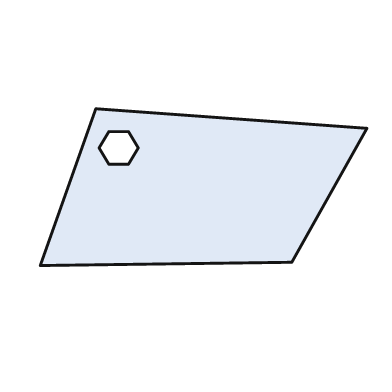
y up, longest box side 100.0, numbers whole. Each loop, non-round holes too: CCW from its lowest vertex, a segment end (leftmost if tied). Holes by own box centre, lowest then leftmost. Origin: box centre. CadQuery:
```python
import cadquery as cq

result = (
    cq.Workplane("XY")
    .moveTo(-50.0, -24.0)
    .lineTo(27.0, -23.0)
    .lineTo(50.0, 18.0)
    .lineTo(-33.0, 24.0)
    .close()
    .moveTo(-29.0, 7.0)
    .lineTo(-23.0, 7.0)
    .lineTo(-20.0, 12.0)
    .lineTo(-23.0, 17.0)
    .lineTo(-29.0, 17.0)
    .lineTo(-32.0, 12.0)
    .close()
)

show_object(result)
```